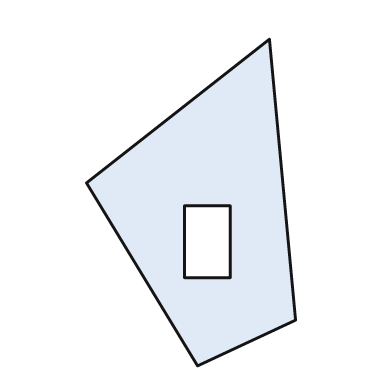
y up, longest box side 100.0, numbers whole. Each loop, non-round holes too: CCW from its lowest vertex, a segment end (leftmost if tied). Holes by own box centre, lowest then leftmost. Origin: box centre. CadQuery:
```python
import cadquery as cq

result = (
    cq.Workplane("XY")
    .moveTo(2.0, -50.0)
    .lineTo(32.0, -36.0)
    .lineTo(24.0, 50.0)
    .lineTo(-32.0, 6.0)
    .close()
    .moveTo(-2.0, -23.0)
    .lineTo(12.0, -23.0)
    .lineTo(12.0, -1.0)
    .lineTo(-2.0, -1.0)
    .close()
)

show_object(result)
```